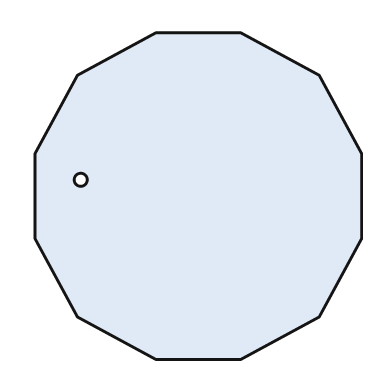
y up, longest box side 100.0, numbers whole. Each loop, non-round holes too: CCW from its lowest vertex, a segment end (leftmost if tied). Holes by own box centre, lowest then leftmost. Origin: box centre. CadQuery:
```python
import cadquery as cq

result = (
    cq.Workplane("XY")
    .moveTo(-13.0, -50.0)
    .lineTo(13.0, -50.0)
    .lineTo(37.0, -37.0)
    .lineTo(50.0, -13.0)
    .lineTo(50.0, 13.0)
    .lineTo(37.0, 37.0)
    .lineTo(13.0, 50.0)
    .lineTo(-13.0, 50.0)
    .lineTo(-37.0, 37.0)
    .lineTo(-50.0, 13.0)
    .lineTo(-50.0, -13.0)
    .lineTo(-37.0, -37.0)
    .close()
    .moveTo(-36.0, 5.0)
    .circle(2.0)
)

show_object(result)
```